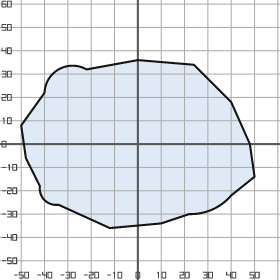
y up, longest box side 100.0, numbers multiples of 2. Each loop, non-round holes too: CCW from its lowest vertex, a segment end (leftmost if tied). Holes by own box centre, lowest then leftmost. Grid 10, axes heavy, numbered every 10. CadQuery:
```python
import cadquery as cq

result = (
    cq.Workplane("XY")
    .moveTo(-12.0, -36.0)
    .lineTo(10.0, -34.0)
    .lineTo(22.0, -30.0)
    .threePointArc((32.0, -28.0), (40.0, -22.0))
    .lineTo(50.0, -14.0)
    .lineTo(48.0, 0.0)
    .lineTo(40.0, 18.0)
    .lineTo(24.0, 34.0)
    .lineTo(0.0, 36.0)
    .lineTo(-22.0, 32.0)
    .threePointArc((-34.0, 32.0), (-40.0, 22.0))
    .lineTo(-50.0, 8.0)
    .lineTo(-48.0, -6.0)
    .lineTo(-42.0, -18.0)
    .threePointArc((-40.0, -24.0), (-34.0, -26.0))
    .close()
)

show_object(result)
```